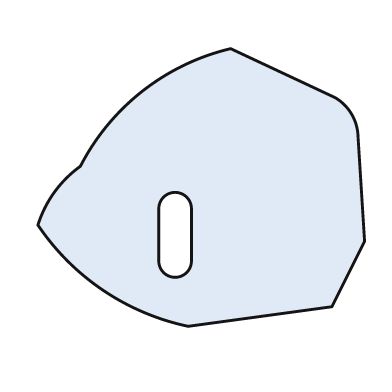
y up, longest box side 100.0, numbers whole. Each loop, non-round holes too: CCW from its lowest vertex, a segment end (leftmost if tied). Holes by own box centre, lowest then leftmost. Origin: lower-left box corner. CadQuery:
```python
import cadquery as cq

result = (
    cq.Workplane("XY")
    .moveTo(46.0, 0.0)
    .lineTo(90.0, 6.0)
    .lineTo(100.0, 26.0)
    .lineTo(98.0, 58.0)
    .threePointArc((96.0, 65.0), (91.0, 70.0))
    .lineTo(59.0, 85.0)
    .threePointArc((32.0, 72.0), (13.0, 49.0))
    .threePointArc((5.0, 41.0), (0.0, 31.0))
    .threePointArc((20.0, 11.0), (46.0, 0.0))
    .close()
    .moveTo(37.0, 20.0)
    .threePointArc((42.0, 15.0), (47.0, 20.0))
    .lineTo(47.0, 36.0)
    .threePointArc((42.0, 41.0), (37.0, 36.0))
    .close()
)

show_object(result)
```